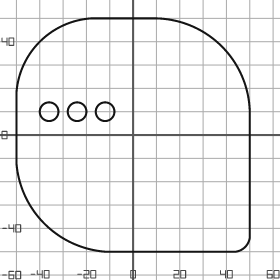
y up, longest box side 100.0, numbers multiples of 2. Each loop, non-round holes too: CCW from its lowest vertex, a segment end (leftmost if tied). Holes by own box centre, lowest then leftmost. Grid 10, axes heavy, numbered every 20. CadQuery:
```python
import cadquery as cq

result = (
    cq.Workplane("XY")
    .moveTo(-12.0, -50.0)
    .lineTo(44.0, -50.0)
    .threePointArc((48.0, -48.0), (50.0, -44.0))
    .lineTo(50.0, 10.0)
    .threePointArc((38.0, 38.0), (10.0, 50.0))
    .lineTo(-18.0, 50.0)
    .threePointArc((-40.0, 40.0), (-50.0, 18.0))
    .lineTo(-50.0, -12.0)
    .threePointArc((-38.0, -38.0), (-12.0, -50.0))
    .close()
    .moveTo(-36.0, 10.0)
    .circle(4.0)
    .moveTo(-24.0, 10.0)
    .circle(4.0)
    .moveTo(-12.0, 10.0)
    .circle(4.0)
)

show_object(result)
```